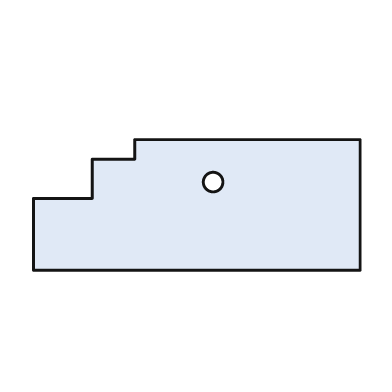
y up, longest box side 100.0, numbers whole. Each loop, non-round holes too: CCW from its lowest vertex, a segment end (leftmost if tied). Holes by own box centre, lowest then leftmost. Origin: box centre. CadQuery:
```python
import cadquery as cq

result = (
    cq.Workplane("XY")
    .moveTo(-50.0, -20.0)
    .lineTo(50.0, -20.0)
    .lineTo(50.0, 20.0)
    .lineTo(-19.0, 20.0)
    .lineTo(-19.0, 14.0)
    .lineTo(-32.0, 14.0)
    .lineTo(-32.0, 2.0)
    .lineTo(-50.0, 2.0)
    .close()
    .moveTo(5.0, 7.0)
    .circle(3.0)
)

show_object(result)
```